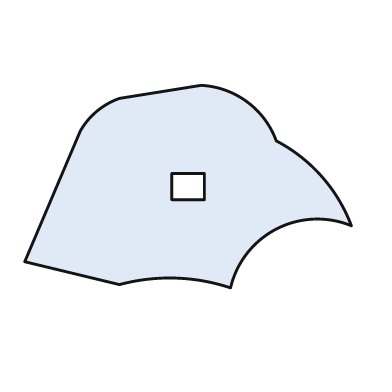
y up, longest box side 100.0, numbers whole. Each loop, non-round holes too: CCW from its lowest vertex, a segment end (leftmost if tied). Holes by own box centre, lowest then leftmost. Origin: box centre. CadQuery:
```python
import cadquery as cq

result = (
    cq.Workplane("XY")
    .moveTo(13.0, -31.0)
    .threePointArc((27.0, -13.0), (50.0, -12.0))
    .threePointArc((41.0, 3.0), (27.0, 14.0))
    .threePointArc((18.0, 26.0), (4.0, 31.0))
    .lineTo(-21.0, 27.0)
    .threePointArc((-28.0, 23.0), (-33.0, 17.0))
    .lineTo(-50.0, -23.0)
    .lineTo(-21.0, -30.0)
    .threePointArc((-4.0, -28.0), (13.0, -31.0))
    .close()
    .moveTo(-5.0, -4.0)
    .lineTo(5.0, -4.0)
    .lineTo(5.0, 4.0)
    .lineTo(-5.0, 4.0)
    .close()
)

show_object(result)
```